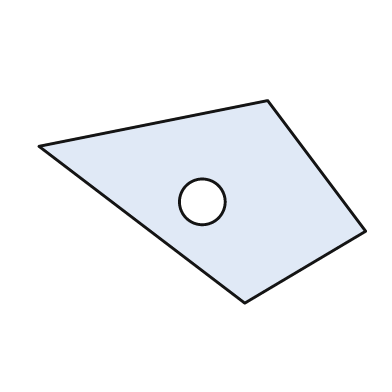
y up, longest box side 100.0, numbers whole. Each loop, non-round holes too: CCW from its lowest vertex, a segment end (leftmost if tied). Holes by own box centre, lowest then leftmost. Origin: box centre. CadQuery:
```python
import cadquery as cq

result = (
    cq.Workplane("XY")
    .moveTo(13.0, -31.0)
    .lineTo(50.0, -9.0)
    .lineTo(20.0, 31.0)
    .lineTo(-50.0, 17.0)
    .close()
    .moveTo(0.0, 0.0)
    .circle(7.0)
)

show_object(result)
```